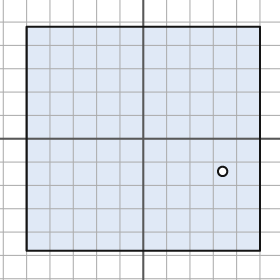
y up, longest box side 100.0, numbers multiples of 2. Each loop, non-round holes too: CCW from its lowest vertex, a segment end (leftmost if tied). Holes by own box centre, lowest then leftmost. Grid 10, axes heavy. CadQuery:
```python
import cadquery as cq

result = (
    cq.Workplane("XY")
    .moveTo(-50.0, -48.0)
    .lineTo(50.0, -48.0)
    .lineTo(50.0, 48.0)
    .lineTo(-50.0, 48.0)
    .close()
    .moveTo(34.0, -14.0)
    .circle(2.0)
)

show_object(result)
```